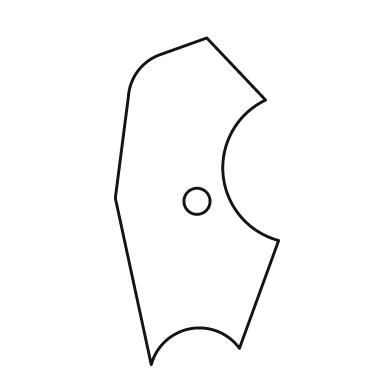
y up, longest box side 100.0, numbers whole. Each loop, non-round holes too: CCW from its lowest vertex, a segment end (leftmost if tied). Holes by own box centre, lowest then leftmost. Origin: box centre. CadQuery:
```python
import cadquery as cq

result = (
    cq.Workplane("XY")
    .moveTo(-14.0, -50.0)
    .threePointArc((-2.0, -39.0), (13.0, -45.0))
    .lineTo(25.0, -12.0)
    .threePointArc((8.0, 8.0), (21.0, 31.0))
    .lineTo(3.0, 50.0)
    .lineTo(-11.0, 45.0)
    .threePointArc((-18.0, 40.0), (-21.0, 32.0))
    .lineTo(-25.0, 1.0)
    .close()
    .moveTo(0.0, 0.0)
    .circle(4.0)
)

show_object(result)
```